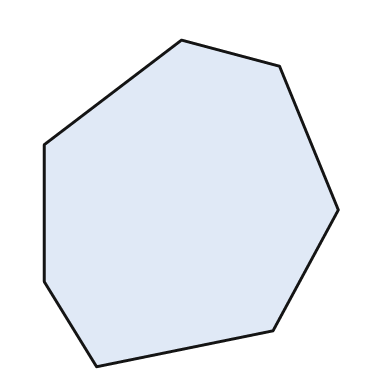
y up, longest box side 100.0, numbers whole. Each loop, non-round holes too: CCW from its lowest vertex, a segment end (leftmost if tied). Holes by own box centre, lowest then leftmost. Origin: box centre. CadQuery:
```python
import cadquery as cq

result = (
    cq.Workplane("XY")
    .moveTo(-29.0, -50.0)
    .lineTo(25.0, -39.0)
    .lineTo(45.0, -2.0)
    .lineTo(27.0, 42.0)
    .lineTo(-3.0, 50.0)
    .lineTo(-45.0, 18.0)
    .lineTo(-45.0, -24.0)
    .close()
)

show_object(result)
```